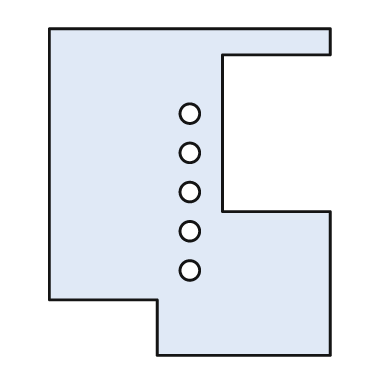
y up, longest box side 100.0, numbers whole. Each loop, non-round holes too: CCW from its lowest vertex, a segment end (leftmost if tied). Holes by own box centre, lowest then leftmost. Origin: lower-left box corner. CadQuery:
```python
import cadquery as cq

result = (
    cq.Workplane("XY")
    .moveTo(33.0, 0.0)
    .lineTo(86.0, 0.0)
    .lineTo(86.0, 44.0)
    .lineTo(53.0, 44.0)
    .lineTo(53.0, 92.0)
    .lineTo(86.0, 92.0)
    .lineTo(86.0, 100.0)
    .lineTo(0.0, 100.0)
    .lineTo(0.0, 17.0)
    .lineTo(33.0, 17.0)
    .close()
    .moveTo(43.0, 26.0)
    .circle(3.0)
    .moveTo(43.0, 38.0)
    .circle(3.0)
    .moveTo(43.0, 50.0)
    .circle(3.0)
    .moveTo(43.0, 62.0)
    .circle(3.0)
    .moveTo(43.0, 74.0)
    .circle(3.0)
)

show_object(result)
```